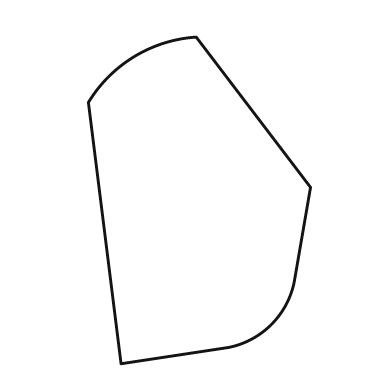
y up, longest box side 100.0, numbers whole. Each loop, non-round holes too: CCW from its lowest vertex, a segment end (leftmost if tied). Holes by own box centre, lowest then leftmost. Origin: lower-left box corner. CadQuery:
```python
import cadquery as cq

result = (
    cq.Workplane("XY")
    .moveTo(10.0, 0.0)
    .lineTo(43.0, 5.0)
    .threePointArc((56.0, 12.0), (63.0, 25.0))
    .lineTo(68.0, 54.0)
    .lineTo(33.0, 100.0)
    .threePointArc((14.0, 94.0), (0.0, 80.0))
    .close()
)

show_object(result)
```